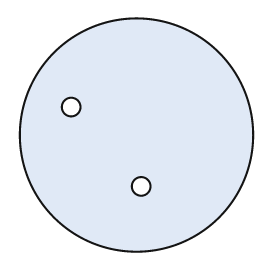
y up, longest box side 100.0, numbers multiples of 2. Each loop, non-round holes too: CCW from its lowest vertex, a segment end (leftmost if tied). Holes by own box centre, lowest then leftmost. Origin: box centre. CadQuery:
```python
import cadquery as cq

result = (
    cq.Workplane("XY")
    .moveTo(0.0, 0.0)
    .circle(50.0)
    .moveTo(2.0, -22.0)
    .circle(4.0)
    .moveTo(-28.0, 12.0)
    .circle(4.0)
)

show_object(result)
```